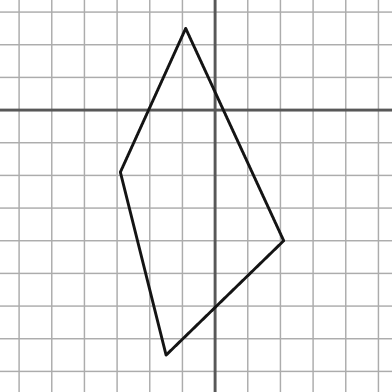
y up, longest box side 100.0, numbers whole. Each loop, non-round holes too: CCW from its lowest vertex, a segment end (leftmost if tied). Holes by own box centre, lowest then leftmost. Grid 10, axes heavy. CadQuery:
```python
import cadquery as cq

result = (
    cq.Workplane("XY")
    .moveTo(-15.0, -75.0)
    .lineTo(21.0, -40.0)
    .lineTo(-9.0, 25.0)
    .lineTo(-29.0, -19.0)
    .close()
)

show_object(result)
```